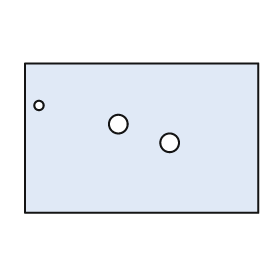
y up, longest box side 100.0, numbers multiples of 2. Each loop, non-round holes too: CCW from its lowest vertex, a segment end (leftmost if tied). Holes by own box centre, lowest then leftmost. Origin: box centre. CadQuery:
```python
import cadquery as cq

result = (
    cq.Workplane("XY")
    .moveTo(-50.0, -32.0)
    .lineTo(50.0, -32.0)
    .lineTo(50.0, 32.0)
    .lineTo(-50.0, 32.0)
    .close()
    .moveTo(12.0, -2.0)
    .circle(4.0)
    .moveTo(-10.0, 6.0)
    .circle(4.0)
    .moveTo(-44.0, 14.0)
    .circle(2.0)
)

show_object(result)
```